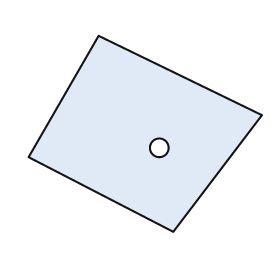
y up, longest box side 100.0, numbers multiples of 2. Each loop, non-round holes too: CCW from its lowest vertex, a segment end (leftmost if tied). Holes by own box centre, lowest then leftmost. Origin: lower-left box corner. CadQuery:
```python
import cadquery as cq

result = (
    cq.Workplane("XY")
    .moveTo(62.0, 0.0)
    .lineTo(100.0, 50.0)
    .lineTo(30.0, 84.0)
    .lineTo(0.0, 32.0)
    .close()
    .moveTo(56.0, 36.0)
    .circle(4.0)
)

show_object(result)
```